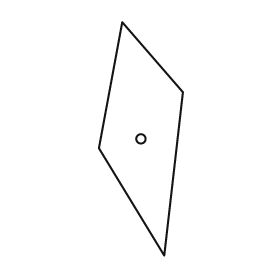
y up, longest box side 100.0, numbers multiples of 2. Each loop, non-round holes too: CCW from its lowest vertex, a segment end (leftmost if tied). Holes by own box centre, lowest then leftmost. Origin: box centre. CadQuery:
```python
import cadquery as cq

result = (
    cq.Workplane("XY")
    .moveTo(10.0, -50.0)
    .lineTo(18.0, 20.0)
    .lineTo(-8.0, 50.0)
    .lineTo(-18.0, -4.0)
    .close()
    .moveTo(0.0, 0.0)
    .circle(2.0)
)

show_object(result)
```